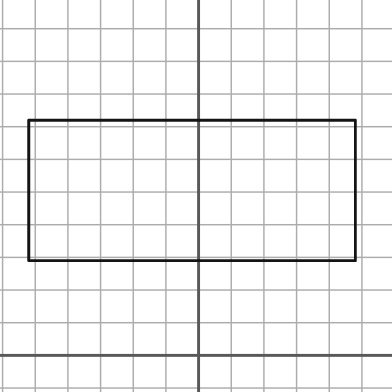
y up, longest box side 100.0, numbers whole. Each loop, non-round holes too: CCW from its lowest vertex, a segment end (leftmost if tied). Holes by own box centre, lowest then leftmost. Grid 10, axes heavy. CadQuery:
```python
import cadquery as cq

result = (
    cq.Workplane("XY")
    .moveTo(-52.0, 29.0)
    .lineTo(48.0, 29.0)
    .lineTo(48.0, 72.0)
    .lineTo(-52.0, 72.0)
    .close()
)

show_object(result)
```